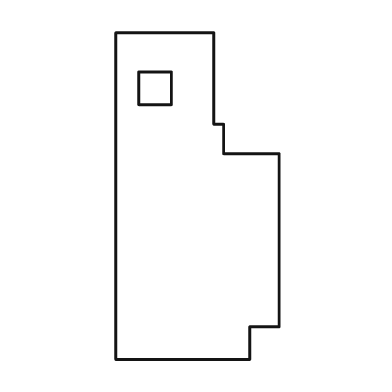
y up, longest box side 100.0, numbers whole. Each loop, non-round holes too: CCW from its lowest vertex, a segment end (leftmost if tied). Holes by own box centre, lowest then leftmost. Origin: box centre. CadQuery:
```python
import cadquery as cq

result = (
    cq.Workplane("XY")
    .moveTo(-25.0, -50.0)
    .lineTo(16.0, -50.0)
    .lineTo(16.0, -40.0)
    .lineTo(25.0, -40.0)
    .lineTo(25.0, 13.0)
    .lineTo(8.0, 13.0)
    .lineTo(8.0, 22.0)
    .lineTo(5.0, 22.0)
    .lineTo(5.0, 50.0)
    .lineTo(-25.0, 50.0)
    .close()
    .moveTo(-18.0, 28.0)
    .lineTo(-8.0, 28.0)
    .lineTo(-8.0, 38.0)
    .lineTo(-18.0, 38.0)
    .close()
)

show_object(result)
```